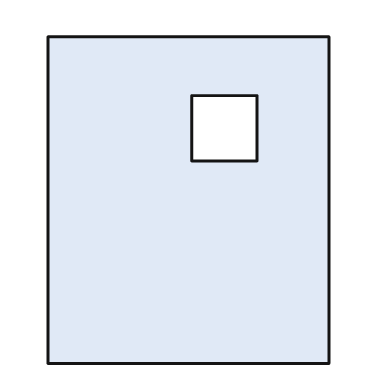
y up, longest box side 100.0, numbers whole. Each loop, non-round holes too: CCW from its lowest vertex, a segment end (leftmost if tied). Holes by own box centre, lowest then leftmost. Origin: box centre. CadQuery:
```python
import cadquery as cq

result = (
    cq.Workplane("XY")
    .moveTo(-43.0, -50.0)
    .lineTo(43.0, -50.0)
    .lineTo(43.0, 50.0)
    .lineTo(-43.0, 50.0)
    .close()
    .moveTo(1.0, 12.0)
    .lineTo(21.0, 12.0)
    .lineTo(21.0, 32.0)
    .lineTo(1.0, 32.0)
    .close()
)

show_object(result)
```